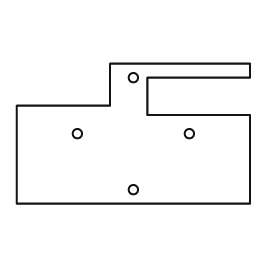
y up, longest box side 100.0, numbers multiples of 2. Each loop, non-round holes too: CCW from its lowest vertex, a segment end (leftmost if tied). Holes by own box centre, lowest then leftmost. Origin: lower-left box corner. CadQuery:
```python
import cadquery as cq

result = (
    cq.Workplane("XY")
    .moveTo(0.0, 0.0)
    .lineTo(100.0, 0.0)
    .lineTo(100.0, 38.0)
    .lineTo(56.0, 38.0)
    .lineTo(56.0, 54.0)
    .lineTo(100.0, 54.0)
    .lineTo(100.0, 60.0)
    .lineTo(40.0, 60.0)
    .lineTo(40.0, 42.0)
    .lineTo(0.0, 42.0)
    .close()
    .moveTo(50.0, 6.0)
    .circle(2.0)
    .moveTo(26.0, 30.0)
    .circle(2.0)
    .moveTo(74.0, 30.0)
    .circle(2.0)
    .moveTo(50.0, 54.0)
    .circle(2.0)
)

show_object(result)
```